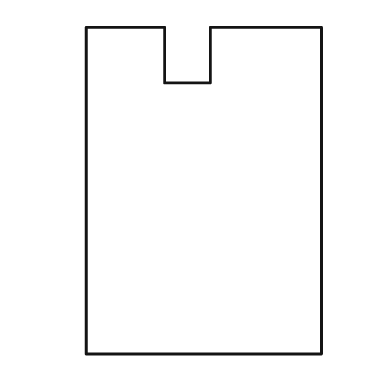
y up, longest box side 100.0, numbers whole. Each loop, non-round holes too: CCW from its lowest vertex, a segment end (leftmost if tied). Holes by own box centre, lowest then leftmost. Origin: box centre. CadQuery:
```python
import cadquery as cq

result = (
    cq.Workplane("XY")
    .moveTo(-36.0, -50.0)
    .lineTo(36.0, -50.0)
    .lineTo(36.0, 50.0)
    .lineTo(2.0, 50.0)
    .lineTo(2.0, 33.0)
    .lineTo(-12.0, 33.0)
    .lineTo(-12.0, 50.0)
    .lineTo(-36.0, 50.0)
    .close()
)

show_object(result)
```